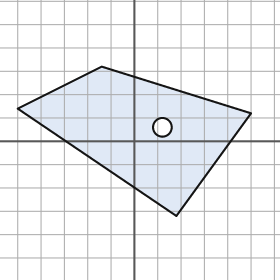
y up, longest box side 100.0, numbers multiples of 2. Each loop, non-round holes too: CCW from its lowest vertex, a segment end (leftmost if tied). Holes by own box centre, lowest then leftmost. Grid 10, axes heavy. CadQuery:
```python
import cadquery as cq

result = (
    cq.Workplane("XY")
    .moveTo(18.0, -32.0)
    .lineTo(50.0, 12.0)
    .lineTo(-14.0, 32.0)
    .lineTo(-50.0, 14.0)
    .close()
    .moveTo(12.0, 6.0)
    .circle(4.0)
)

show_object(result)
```